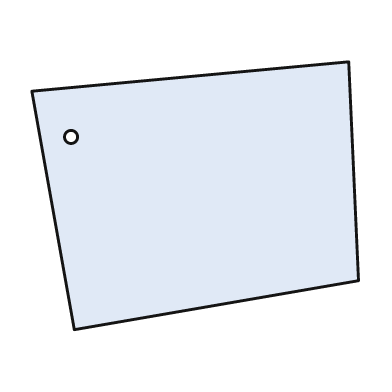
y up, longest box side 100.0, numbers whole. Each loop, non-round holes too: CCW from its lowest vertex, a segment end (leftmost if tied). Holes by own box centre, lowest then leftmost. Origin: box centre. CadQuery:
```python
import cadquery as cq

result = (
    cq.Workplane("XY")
    .moveTo(-37.0, -41.0)
    .lineTo(50.0, -26.0)
    .lineTo(47.0, 41.0)
    .lineTo(-50.0, 32.0)
    .close()
    .moveTo(-38.0, 18.0)
    .circle(2.0)
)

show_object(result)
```